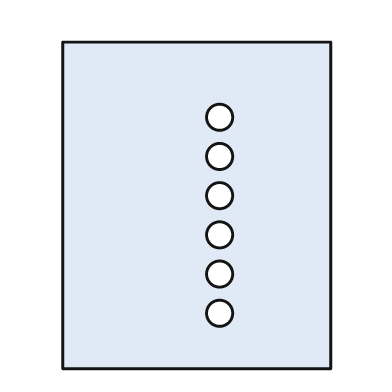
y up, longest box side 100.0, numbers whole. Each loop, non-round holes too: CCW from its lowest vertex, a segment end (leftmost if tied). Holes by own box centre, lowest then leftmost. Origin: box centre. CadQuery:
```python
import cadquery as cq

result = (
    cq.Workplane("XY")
    .moveTo(-41.0, -50.0)
    .lineTo(41.0, -50.0)
    .lineTo(41.0, 50.0)
    .lineTo(-41.0, 50.0)
    .close()
    .moveTo(7.0, -33.0)
    .circle(4.0)
    .moveTo(7.0, -21.0)
    .circle(4.0)
    .moveTo(7.0, -9.0)
    .circle(4.0)
    .moveTo(7.0, 3.0)
    .circle(4.0)
    .moveTo(7.0, 15.0)
    .circle(4.0)
    .moveTo(7.0, 27.0)
    .circle(4.0)
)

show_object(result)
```